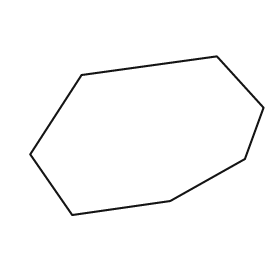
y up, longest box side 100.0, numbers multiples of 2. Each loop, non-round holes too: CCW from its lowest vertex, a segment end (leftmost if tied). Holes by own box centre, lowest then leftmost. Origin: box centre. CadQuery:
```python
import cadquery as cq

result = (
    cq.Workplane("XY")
    .moveTo(-32.0, -34.0)
    .lineTo(10.0, -28.0)
    .lineTo(42.0, -10.0)
    .lineTo(50.0, 12.0)
    .lineTo(30.0, 34.0)
    .lineTo(-28.0, 26.0)
    .lineTo(-50.0, -8.0)
    .close()
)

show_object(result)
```